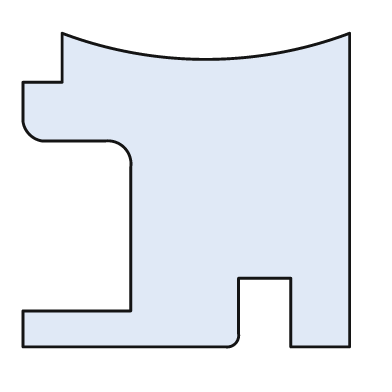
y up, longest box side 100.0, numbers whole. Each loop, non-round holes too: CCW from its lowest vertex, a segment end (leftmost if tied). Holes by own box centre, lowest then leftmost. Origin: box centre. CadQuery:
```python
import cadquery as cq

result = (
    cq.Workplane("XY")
    .moveTo(-50.0, -48.0)
    .lineTo(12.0, -48.0)
    .threePointArc((15.0, -47.0), (16.0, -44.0))
    .lineTo(16.0, -27.0)
    .lineTo(32.0, -27.0)
    .lineTo(32.0, -48.0)
    .lineTo(50.0, -48.0)
    .lineTo(50.0, 48.0)
    .threePointArc((6.0, 40.0), (-38.0, 48.0))
    .lineTo(-38.0, 33.0)
    .lineTo(-50.0, 33.0)
    .lineTo(-50.0, 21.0)
    .threePointArc((-48.0, 17.0), (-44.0, 15.0))
    .lineTo(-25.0, 15.0)
    .threePointArc((-19.0, 13.0), (-17.0, 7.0))
    .lineTo(-17.0, -37.0)
    .lineTo(-50.0, -37.0)
    .close()
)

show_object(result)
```